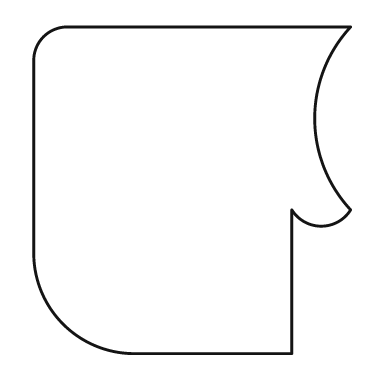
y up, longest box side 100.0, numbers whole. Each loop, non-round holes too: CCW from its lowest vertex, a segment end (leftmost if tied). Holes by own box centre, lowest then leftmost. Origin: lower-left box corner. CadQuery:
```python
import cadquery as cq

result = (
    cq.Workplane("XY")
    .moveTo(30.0, 0.0)
    .lineTo(79.0, 0.0)
    .lineTo(79.0, 44.0)
    .threePointArc((88.0, 39.0), (97.0, 44.0))
    .threePointArc((86.0, 72.0), (97.0, 100.0))
    .lineTo(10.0, 100.0)
    .threePointArc((3.0, 97.0), (0.0, 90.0))
    .lineTo(0.0, 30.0)
    .threePointArc((9.0, 9.0), (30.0, 0.0))
    .close()
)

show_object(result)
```